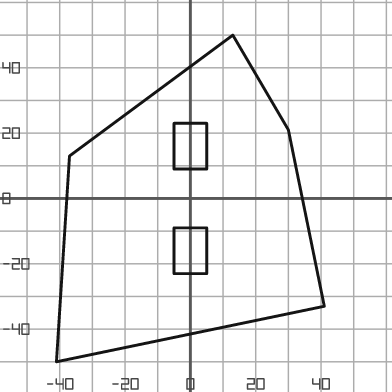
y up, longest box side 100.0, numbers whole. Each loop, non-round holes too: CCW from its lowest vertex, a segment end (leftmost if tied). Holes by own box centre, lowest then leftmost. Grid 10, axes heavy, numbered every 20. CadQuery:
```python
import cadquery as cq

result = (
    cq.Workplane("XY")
    .moveTo(-41.0, -50.0)
    .lineTo(41.0, -33.0)
    .lineTo(30.0, 21.0)
    .lineTo(13.0, 50.0)
    .lineTo(-37.0, 13.0)
    .close()
    .moveTo(-5.0, -23.0)
    .lineTo(5.0, -23.0)
    .lineTo(5.0, -9.0)
    .lineTo(-5.0, -9.0)
    .close()
    .moveTo(-5.0, 9.0)
    .lineTo(5.0, 9.0)
    .lineTo(5.0, 23.0)
    .lineTo(-5.0, 23.0)
    .close()
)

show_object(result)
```